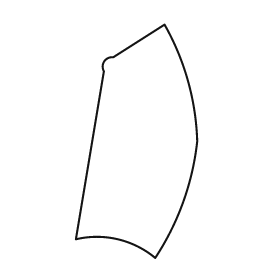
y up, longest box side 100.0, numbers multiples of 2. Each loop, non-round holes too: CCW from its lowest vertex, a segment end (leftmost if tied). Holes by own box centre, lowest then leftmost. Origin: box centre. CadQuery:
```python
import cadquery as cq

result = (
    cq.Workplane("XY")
    .moveTo(8.0, -50.0)
    .threePointArc((20.0, -26.0), (26.0, 0.0))
    .threePointArc((22.0, 26.0), (12.0, 50.0))
    .lineTo(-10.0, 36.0)
    .threePointArc((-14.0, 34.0), (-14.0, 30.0))
    .lineTo(-26.0, -42.0)
    .threePointArc((-8.0, -42.0), (8.0, -50.0))
    .close()
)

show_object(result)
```